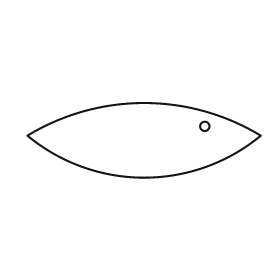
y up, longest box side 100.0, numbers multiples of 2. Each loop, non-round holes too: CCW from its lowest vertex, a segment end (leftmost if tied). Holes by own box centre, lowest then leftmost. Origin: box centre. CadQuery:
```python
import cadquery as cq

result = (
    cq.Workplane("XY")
    .moveTo(-50.0, 2.0)
    .threePointArc((0.0, -16.0), (50.0, 2.0))
    .threePointArc((0.0, 16.0), (-50.0, 2.0))
    .close()
    .moveTo(26.0, 6.0)
    .circle(2.0)
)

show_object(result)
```